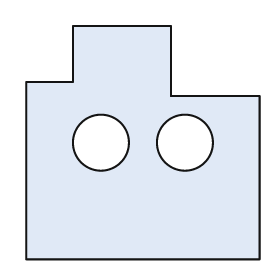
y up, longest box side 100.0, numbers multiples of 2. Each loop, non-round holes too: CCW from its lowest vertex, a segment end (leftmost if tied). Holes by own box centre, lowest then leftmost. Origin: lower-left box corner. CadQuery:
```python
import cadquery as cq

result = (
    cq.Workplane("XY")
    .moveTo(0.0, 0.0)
    .lineTo(100.0, 0.0)
    .lineTo(100.0, 70.0)
    .lineTo(62.0, 70.0)
    .lineTo(62.0, 100.0)
    .lineTo(20.0, 100.0)
    .lineTo(20.0, 76.0)
    .lineTo(0.0, 76.0)
    .close()
    .moveTo(32.0, 50.0)
    .circle(12.0)
    .moveTo(68.0, 50.0)
    .circle(12.0)
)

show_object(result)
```